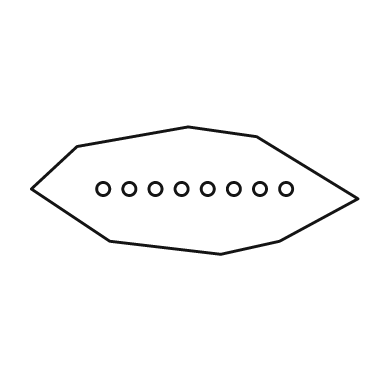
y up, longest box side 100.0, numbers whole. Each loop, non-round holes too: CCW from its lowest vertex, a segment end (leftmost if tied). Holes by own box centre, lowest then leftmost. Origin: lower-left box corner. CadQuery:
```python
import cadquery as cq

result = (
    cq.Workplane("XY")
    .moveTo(58.0, 0.0)
    .lineTo(76.0, 4.0)
    .lineTo(100.0, 17.0)
    .lineTo(69.0, 36.0)
    .lineTo(48.0, 39.0)
    .lineTo(14.0, 33.0)
    .lineTo(0.0, 20.0)
    .lineTo(24.0, 4.0)
    .close()
    .moveTo(22.0, 20.0)
    .circle(2.0)
    .moveTo(30.0, 20.0)
    .circle(2.0)
    .moveTo(38.0, 20.0)
    .circle(2.0)
    .moveTo(46.0, 20.0)
    .circle(2.0)
    .moveTo(54.0, 20.0)
    .circle(2.0)
    .moveTo(62.0, 20.0)
    .circle(2.0)
    .moveTo(70.0, 20.0)
    .circle(2.0)
    .moveTo(78.0, 20.0)
    .circle(2.0)
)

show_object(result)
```